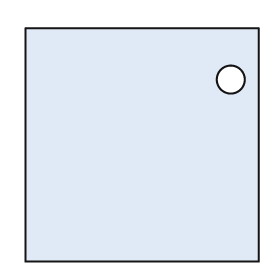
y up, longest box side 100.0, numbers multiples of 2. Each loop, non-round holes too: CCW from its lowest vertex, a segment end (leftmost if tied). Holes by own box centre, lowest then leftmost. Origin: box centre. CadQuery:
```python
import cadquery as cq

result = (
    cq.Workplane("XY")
    .moveTo(-50.0, -50.0)
    .lineTo(50.0, -50.0)
    .lineTo(50.0, 50.0)
    .lineTo(-50.0, 50.0)
    .close()
    .moveTo(38.0, 28.0)
    .circle(6.0)
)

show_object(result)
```